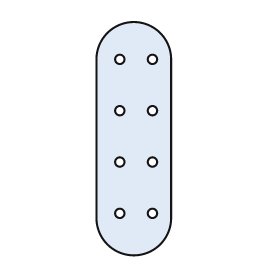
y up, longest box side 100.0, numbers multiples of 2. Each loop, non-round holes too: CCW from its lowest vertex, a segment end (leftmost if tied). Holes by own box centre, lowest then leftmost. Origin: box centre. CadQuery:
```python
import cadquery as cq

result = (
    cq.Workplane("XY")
    .moveTo(-16.0, -34.0)
    .threePointArc((0.0, -50.0), (16.0, -34.0))
    .lineTo(16.0, 34.0)
    .threePointArc((0.0, 50.0), (-16.0, 34.0))
    .close()
    .moveTo(-6.0, -32.0)
    .circle(2.0)
    .moveTo(8.0, -32.0)
    .circle(2.0)
    .moveTo(-6.0, -10.0)
    .circle(2.0)
    .moveTo(8.0, -10.0)
    .circle(2.0)
    .moveTo(-6.0, 12.0)
    .circle(2.0)
    .moveTo(8.0, 12.0)
    .circle(2.0)
    .moveTo(-6.0, 34.0)
    .circle(2.0)
    .moveTo(8.0, 34.0)
    .circle(2.0)
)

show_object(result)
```